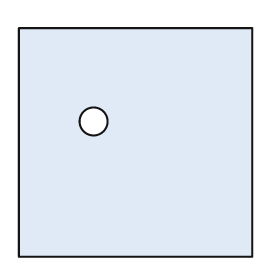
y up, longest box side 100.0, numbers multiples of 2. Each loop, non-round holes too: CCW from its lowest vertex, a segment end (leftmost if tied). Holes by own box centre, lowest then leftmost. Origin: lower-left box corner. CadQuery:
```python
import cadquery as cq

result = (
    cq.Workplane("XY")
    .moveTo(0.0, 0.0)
    .lineTo(100.0, 0.0)
    .lineTo(100.0, 98.0)
    .lineTo(0.0, 98.0)
    .close()
    .moveTo(32.0, 58.0)
    .circle(6.0)
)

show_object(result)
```